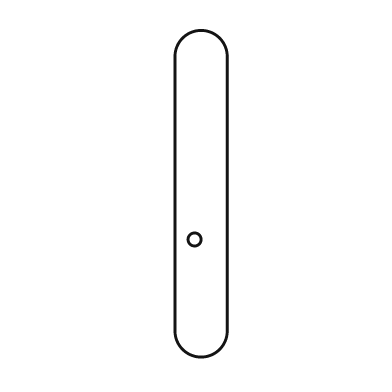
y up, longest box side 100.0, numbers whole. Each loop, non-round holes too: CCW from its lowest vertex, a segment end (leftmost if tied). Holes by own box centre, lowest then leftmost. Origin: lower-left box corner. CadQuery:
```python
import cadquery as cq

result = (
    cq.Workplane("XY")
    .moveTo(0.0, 8.0)
    .threePointArc((8.0, 0.0), (16.0, 8.0))
    .lineTo(16.0, 92.0)
    .threePointArc((8.0, 100.0), (0.0, 92.0))
    .close()
    .moveTo(6.0, 36.0)
    .circle(2.0)
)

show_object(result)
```